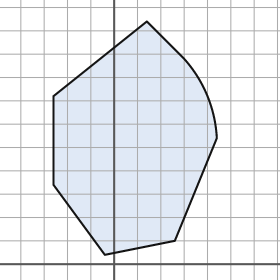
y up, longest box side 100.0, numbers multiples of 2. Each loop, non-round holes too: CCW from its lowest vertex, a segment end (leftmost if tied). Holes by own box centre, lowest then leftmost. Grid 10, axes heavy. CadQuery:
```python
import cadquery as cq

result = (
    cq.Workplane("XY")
    .moveTo(-4.0, 4.0)
    .lineTo(26.0, 10.0)
    .lineTo(44.0, 54.0)
    .threePointArc((40.0, 72.0), (30.0, 88.0))
    .lineTo(14.0, 104.0)
    .lineTo(-26.0, 72.0)
    .lineTo(-26.0, 34.0)
    .close()
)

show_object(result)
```